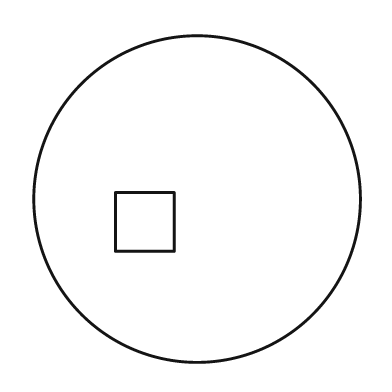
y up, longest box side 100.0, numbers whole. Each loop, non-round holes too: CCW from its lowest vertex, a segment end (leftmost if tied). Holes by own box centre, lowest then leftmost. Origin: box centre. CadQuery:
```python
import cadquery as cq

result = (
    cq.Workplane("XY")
    .moveTo(0.0, 0.0)
    .circle(50.0)
    .moveTo(-25.0, -16.0)
    .lineTo(-7.0, -16.0)
    .lineTo(-7.0, 2.0)
    .lineTo(-25.0, 2.0)
    .close()
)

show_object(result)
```